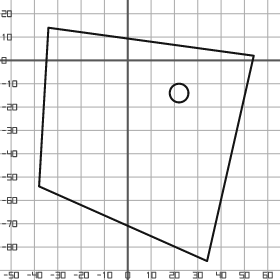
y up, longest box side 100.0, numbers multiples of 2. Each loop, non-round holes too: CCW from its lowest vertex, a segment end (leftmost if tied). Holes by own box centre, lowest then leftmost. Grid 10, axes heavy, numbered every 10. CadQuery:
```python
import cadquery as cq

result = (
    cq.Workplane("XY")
    .moveTo(34.0, -86.0)
    .lineTo(54.0, 2.0)
    .lineTo(-34.0, 14.0)
    .lineTo(-38.0, -54.0)
    .close()
    .moveTo(22.0, -14.0)
    .circle(4.0)
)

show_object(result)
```